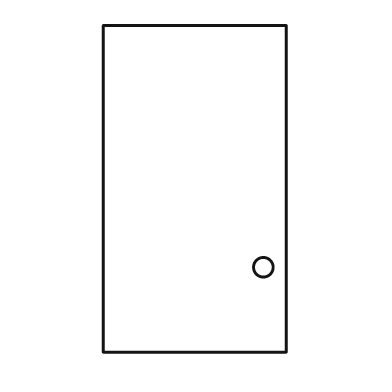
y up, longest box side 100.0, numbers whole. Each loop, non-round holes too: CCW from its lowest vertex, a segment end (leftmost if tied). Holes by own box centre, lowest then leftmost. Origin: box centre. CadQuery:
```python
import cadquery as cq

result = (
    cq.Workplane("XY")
    .moveTo(-28.0, -50.0)
    .lineTo(28.0, -50.0)
    .lineTo(28.0, 50.0)
    .lineTo(-28.0, 50.0)
    .close()
    .moveTo(21.0, -24.0)
    .circle(3.0)
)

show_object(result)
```